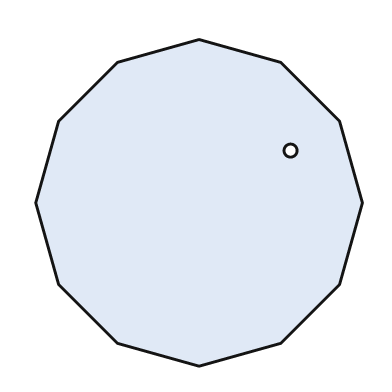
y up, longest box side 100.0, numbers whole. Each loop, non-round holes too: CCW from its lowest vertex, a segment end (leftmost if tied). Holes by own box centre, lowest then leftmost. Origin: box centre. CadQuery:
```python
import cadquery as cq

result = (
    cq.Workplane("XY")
    .moveTo(0.0, -50.0)
    .lineTo(25.0, -43.0)
    .lineTo(43.0, -25.0)
    .lineTo(50.0, 0.0)
    .lineTo(43.0, 25.0)
    .lineTo(25.0, 43.0)
    .lineTo(0.0, 50.0)
    .lineTo(-25.0, 43.0)
    .lineTo(-43.0, 25.0)
    .lineTo(-50.0, 0.0)
    .lineTo(-43.0, -25.0)
    .lineTo(-25.0, -43.0)
    .close()
    .moveTo(28.0, 16.0)
    .circle(2.0)
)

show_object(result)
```